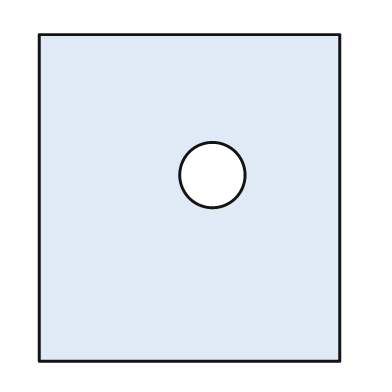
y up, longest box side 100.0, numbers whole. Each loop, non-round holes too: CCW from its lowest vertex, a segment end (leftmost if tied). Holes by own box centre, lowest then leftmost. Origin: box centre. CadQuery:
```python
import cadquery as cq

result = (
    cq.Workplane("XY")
    .moveTo(-46.0, -50.0)
    .lineTo(46.0, -50.0)
    .lineTo(46.0, 50.0)
    .lineTo(-46.0, 50.0)
    .close()
    .moveTo(7.0, 7.0)
    .circle(10.0)
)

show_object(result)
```